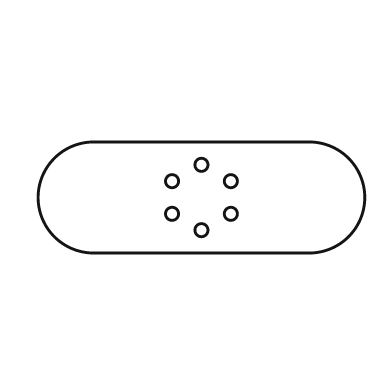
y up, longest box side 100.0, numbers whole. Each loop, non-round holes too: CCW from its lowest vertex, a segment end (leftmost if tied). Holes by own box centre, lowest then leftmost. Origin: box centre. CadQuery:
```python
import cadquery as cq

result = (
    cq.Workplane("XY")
    .moveTo(-33.0, -17.0)
    .lineTo(33.0, -17.0)
    .threePointArc((50.0, 0.0), (33.0, 17.0))
    .lineTo(-33.0, 17.0)
    .threePointArc((-50.0, 0.0), (-33.0, -17.0))
    .close()
    .moveTo(0.0, -10.0)
    .circle(2.0)
    .moveTo(-9.0, -5.0)
    .circle(2.0)
    .moveTo(9.0, -5.0)
    .circle(2.0)
    .moveTo(-9.0, 5.0)
    .circle(2.0)
    .moveTo(9.0, 5.0)
    .circle(2.0)
    .moveTo(0.0, 10.0)
    .circle(2.0)
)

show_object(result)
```